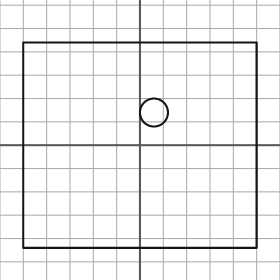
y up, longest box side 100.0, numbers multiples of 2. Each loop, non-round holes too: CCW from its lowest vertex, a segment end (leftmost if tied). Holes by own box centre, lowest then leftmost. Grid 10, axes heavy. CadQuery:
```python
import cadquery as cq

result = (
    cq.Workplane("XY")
    .moveTo(-50.0, -44.0)
    .lineTo(50.0, -44.0)
    .lineTo(50.0, 44.0)
    .lineTo(-50.0, 44.0)
    .close()
    .moveTo(6.0, 14.0)
    .circle(6.0)
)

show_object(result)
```